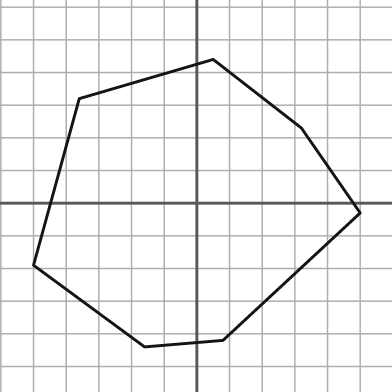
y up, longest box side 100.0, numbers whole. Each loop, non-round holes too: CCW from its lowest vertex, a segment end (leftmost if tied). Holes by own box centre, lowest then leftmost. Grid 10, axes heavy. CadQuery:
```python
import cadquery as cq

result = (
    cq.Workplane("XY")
    .moveTo(-16.0, -44.0)
    .lineTo(8.0, -42.0)
    .lineTo(50.0, -3.0)
    .lineTo(32.0, 23.0)
    .lineTo(5.0, 44.0)
    .lineTo(-36.0, 32.0)
    .lineTo(-50.0, -19.0)
    .close()
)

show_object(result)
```